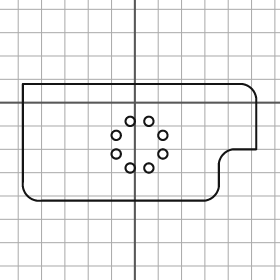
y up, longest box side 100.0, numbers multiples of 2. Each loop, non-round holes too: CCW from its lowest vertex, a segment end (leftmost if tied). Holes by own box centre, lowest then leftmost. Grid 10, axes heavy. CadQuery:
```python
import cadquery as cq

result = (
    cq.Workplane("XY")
    .moveTo(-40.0, -42.0)
    .lineTo(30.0, -42.0)
    .threePointArc((34.0, -40.0), (36.0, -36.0))
    .lineTo(36.0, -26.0)
    .threePointArc((38.0, -22.0), (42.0, -20.0))
    .lineTo(52.0, -20.0)
    .lineTo(52.0, 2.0)
    .threePointArc((50.0, 6.0), (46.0, 8.0))
    .lineTo(-48.0, 8.0)
    .lineTo(-48.0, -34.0)
    .threePointArc((-46.0, -40.0), (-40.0, -42.0))
    .close()
    .moveTo(-2.0, -28.0)
    .circle(2.0)
    .moveTo(6.0, -28.0)
    .circle(2.0)
    .moveTo(-8.0, -22.0)
    .circle(2.0)
    .moveTo(12.0, -22.0)
    .circle(2.0)
    .moveTo(-8.0, -14.0)
    .circle(2.0)
    .moveTo(12.0, -14.0)
    .circle(2.0)
    .moveTo(-2.0, -8.0)
    .circle(2.0)
    .moveTo(6.0, -8.0)
    .circle(2.0)
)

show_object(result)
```